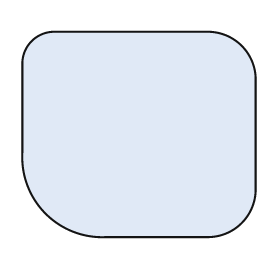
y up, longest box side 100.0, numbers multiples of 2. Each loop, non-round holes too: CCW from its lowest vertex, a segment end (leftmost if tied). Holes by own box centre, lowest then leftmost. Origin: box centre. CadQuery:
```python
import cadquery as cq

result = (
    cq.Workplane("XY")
    .moveTo(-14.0, -44.0)
    .lineTo(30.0, -44.0)
    .threePointArc((44.0, -38.0), (50.0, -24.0))
    .lineTo(50.0, 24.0)
    .threePointArc((44.0, 38.0), (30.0, 44.0))
    .lineTo(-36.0, 44.0)
    .threePointArc((-46.0, 40.0), (-50.0, 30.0))
    .lineTo(-50.0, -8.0)
    .threePointArc((-40.0, -34.0), (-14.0, -44.0))
    .close()
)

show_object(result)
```